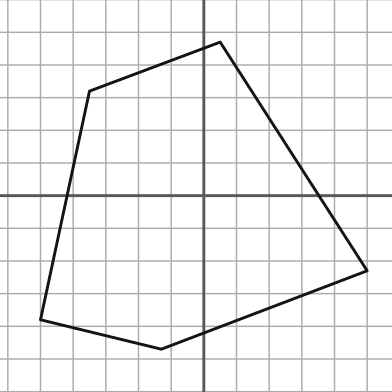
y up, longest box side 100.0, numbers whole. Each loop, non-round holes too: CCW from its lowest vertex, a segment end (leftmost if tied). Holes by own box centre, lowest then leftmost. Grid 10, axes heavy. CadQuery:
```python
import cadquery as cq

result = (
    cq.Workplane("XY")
    .moveTo(-13.0, -47.0)
    .lineTo(50.0, -23.0)
    .lineTo(5.0, 47.0)
    .lineTo(-35.0, 32.0)
    .lineTo(-50.0, -38.0)
    .close()
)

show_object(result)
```